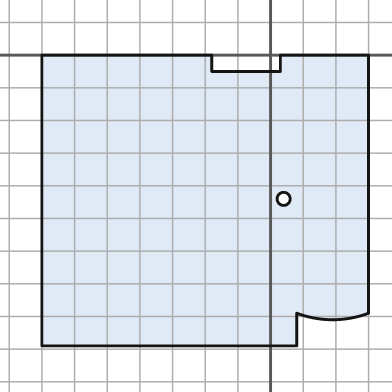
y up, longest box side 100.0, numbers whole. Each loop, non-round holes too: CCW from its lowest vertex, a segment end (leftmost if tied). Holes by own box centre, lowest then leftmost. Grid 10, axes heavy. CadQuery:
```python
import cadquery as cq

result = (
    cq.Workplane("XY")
    .moveTo(-70.0, -89.0)
    .lineTo(8.0, -89.0)
    .lineTo(8.0, -79.0)
    .threePointArc((19.0, -81.0), (30.0, -79.0))
    .lineTo(30.0, 0.0)
    .lineTo(3.0, 0.0)
    .lineTo(3.0, -5.0)
    .lineTo(-18.0, -5.0)
    .lineTo(-18.0, 0.0)
    .lineTo(-70.0, 0.0)
    .close()
    .moveTo(4.0, -44.0)
    .circle(2.0)
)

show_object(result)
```